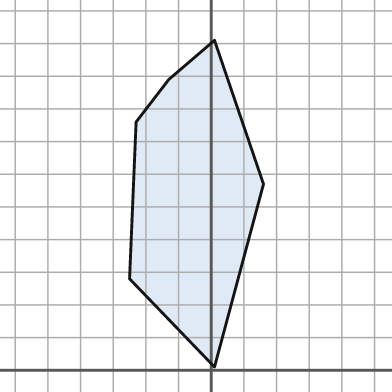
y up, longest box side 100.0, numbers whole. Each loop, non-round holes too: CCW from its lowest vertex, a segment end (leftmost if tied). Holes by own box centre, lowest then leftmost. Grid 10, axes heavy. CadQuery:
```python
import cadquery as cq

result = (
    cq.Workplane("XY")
    .moveTo(1.0, 1.0)
    .lineTo(16.0, 57.0)
    .lineTo(1.0, 101.0)
    .lineTo(-13.0, 89.0)
    .lineTo(-23.0, 76.0)
    .lineTo(-25.0, 28.0)
    .close()
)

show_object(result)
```